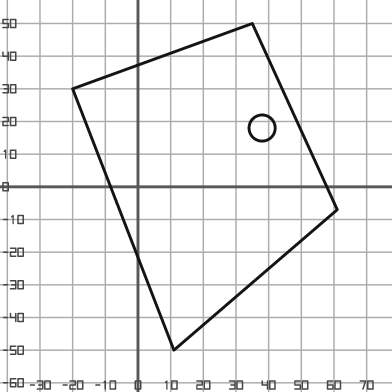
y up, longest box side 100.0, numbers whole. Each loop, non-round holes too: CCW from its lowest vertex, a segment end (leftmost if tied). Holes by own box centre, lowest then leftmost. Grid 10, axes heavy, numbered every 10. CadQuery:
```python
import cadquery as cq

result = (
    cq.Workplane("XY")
    .moveTo(11.0, -50.0)
    .lineTo(61.0, -7.0)
    .lineTo(35.0, 50.0)
    .lineTo(-20.0, 30.0)
    .close()
    .moveTo(38.0, 18.0)
    .circle(4.0)
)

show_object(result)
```